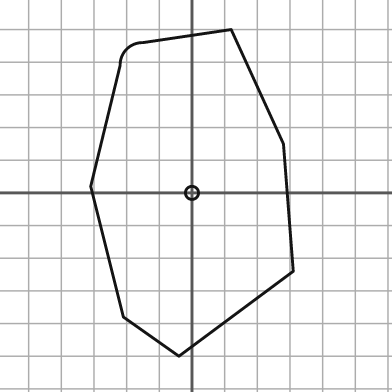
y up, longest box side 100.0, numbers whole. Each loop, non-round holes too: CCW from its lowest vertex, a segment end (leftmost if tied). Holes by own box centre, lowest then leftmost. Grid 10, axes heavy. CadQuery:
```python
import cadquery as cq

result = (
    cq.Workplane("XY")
    .moveTo(-4.0, -50.0)
    .lineTo(31.0, -24.0)
    .lineTo(28.0, 15.0)
    .lineTo(12.0, 50.0)
    .lineTo(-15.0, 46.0)
    .threePointArc((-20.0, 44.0), (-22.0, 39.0))
    .lineTo(-31.0, 2.0)
    .lineTo(-21.0, -38.0)
    .close()
    .moveTo(0.0, 0.0)
    .circle(2.0)
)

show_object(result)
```